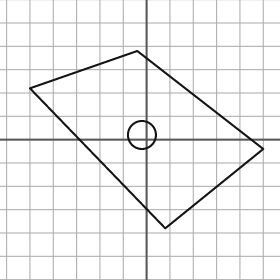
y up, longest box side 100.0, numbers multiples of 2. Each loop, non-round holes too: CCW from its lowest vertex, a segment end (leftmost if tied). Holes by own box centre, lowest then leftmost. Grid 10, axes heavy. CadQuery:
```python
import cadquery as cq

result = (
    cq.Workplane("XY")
    .moveTo(8.0, -38.0)
    .lineTo(50.0, -4.0)
    .lineTo(-4.0, 38.0)
    .lineTo(-50.0, 22.0)
    .close()
    .moveTo(-2.0, 2.0)
    .circle(6.0)
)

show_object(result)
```